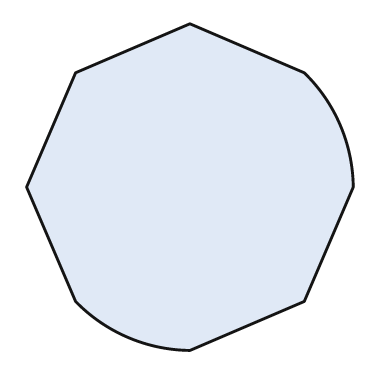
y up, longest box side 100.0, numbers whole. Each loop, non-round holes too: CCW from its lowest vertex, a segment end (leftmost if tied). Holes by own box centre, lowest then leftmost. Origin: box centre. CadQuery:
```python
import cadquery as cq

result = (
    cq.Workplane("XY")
    .moveTo(0.0, -50.0)
    .lineTo(35.0, -35.0)
    .lineTo(50.0, 0.0)
    .threePointArc((46.0, 19.0), (35.0, 35.0))
    .lineTo(0.0, 50.0)
    .lineTo(-35.0, 35.0)
    .lineTo(-50.0, 0.0)
    .lineTo(-35.0, -35.0)
    .threePointArc((-19.0, -46.0), (0.0, -50.0))
    .close()
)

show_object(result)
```